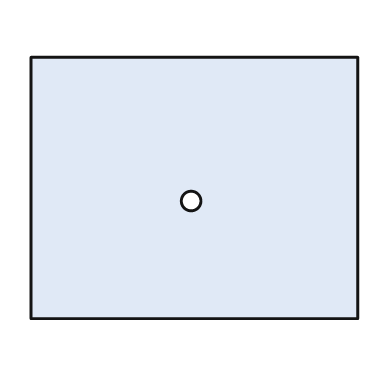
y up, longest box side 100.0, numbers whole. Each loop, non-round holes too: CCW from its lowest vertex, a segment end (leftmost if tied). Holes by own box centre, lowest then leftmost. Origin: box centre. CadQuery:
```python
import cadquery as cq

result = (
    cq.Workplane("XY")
    .moveTo(-50.0, -40.0)
    .lineTo(50.0, -40.0)
    .lineTo(50.0, 40.0)
    .lineTo(-50.0, 40.0)
    .close()
    .moveTo(-1.0, -4.0)
    .circle(3.0)
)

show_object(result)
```